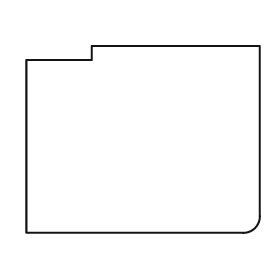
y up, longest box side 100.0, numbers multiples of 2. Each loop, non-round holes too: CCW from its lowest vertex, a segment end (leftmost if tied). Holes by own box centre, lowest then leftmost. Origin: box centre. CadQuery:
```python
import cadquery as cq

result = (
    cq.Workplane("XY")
    .moveTo(-50.0, -40.0)
    .lineTo(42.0, -40.0)
    .threePointArc((48.0, -38.0), (50.0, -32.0))
    .lineTo(50.0, 40.0)
    .lineTo(-22.0, 40.0)
    .lineTo(-22.0, 34.0)
    .lineTo(-50.0, 34.0)
    .close()
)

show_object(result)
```